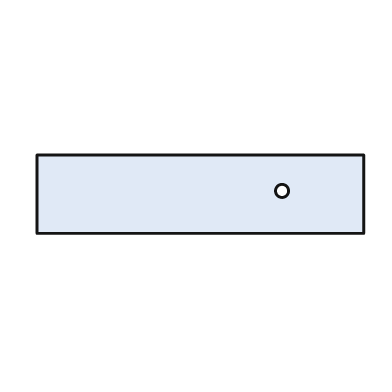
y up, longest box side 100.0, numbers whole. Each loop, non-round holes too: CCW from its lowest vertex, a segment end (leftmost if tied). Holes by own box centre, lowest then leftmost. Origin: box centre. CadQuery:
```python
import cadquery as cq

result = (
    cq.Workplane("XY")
    .moveTo(-50.0, -12.0)
    .lineTo(50.0, -12.0)
    .lineTo(50.0, 12.0)
    .lineTo(-50.0, 12.0)
    .close()
    .moveTo(25.0, 1.0)
    .circle(2.0)
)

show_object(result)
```